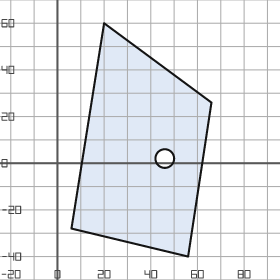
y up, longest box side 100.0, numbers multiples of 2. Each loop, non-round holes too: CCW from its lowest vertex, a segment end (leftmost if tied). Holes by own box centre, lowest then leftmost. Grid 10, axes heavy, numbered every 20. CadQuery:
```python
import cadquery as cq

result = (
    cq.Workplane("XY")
    .moveTo(56.0, -40.0)
    .lineTo(66.0, 26.0)
    .lineTo(20.0, 60.0)
    .lineTo(6.0, -28.0)
    .close()
    .moveTo(46.0, 2.0)
    .circle(4.0)
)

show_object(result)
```